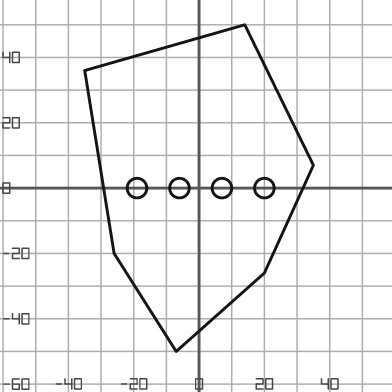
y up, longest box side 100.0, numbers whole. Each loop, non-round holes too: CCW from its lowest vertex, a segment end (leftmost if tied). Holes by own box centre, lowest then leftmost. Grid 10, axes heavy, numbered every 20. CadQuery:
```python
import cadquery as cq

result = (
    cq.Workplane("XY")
    .moveTo(-7.0, -50.0)
    .lineTo(20.0, -26.0)
    .lineTo(35.0, 7.0)
    .lineTo(14.0, 50.0)
    .lineTo(-35.0, 36.0)
    .lineTo(-26.0, -20.0)
    .close()
    .moveTo(-19.0, 0.0)
    .circle(3.0)
    .moveTo(-6.0, 0.0)
    .circle(3.0)
    .moveTo(7.0, 0.0)
    .circle(3.0)
    .moveTo(20.0, 0.0)
    .circle(3.0)
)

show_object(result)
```